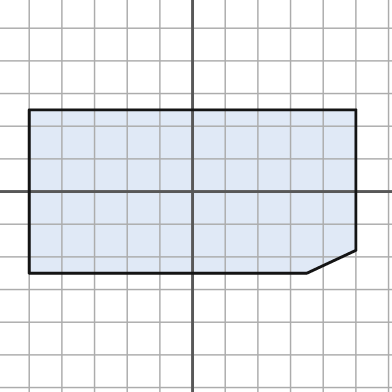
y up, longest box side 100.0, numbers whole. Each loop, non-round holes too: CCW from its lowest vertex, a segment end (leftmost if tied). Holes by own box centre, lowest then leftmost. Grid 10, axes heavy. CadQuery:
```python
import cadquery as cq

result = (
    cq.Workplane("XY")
    .moveTo(-50.0, -25.0)
    .lineTo(35.0, -25.0)
    .lineTo(50.0, -18.0)
    .lineTo(50.0, 25.0)
    .lineTo(-50.0, 25.0)
    .close()
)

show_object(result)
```